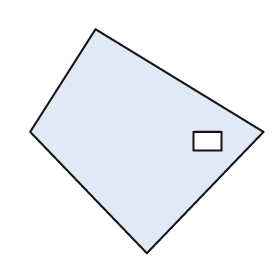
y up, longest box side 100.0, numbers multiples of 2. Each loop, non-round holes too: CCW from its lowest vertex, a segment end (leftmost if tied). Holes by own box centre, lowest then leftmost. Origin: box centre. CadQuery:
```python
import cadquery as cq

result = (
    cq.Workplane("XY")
    .moveTo(0.0, -48.0)
    .lineTo(50.0, 4.0)
    .lineTo(-22.0, 48.0)
    .lineTo(-50.0, 4.0)
    .close()
    .moveTo(20.0, -4.0)
    .lineTo(32.0, -4.0)
    .lineTo(32.0, 4.0)
    .lineTo(20.0, 4.0)
    .close()
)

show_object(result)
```